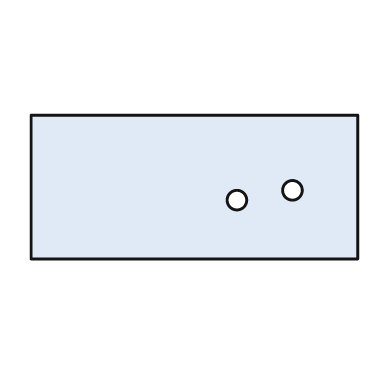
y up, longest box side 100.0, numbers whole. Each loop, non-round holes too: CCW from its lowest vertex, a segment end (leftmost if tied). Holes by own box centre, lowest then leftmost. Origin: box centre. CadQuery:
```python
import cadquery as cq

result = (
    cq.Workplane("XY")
    .moveTo(-50.0, -22.0)
    .lineTo(50.0, -22.0)
    .lineTo(50.0, 22.0)
    .lineTo(-50.0, 22.0)
    .close()
    .moveTo(13.0, -4.0)
    .circle(3.0)
    .moveTo(30.0, -1.0)
    .circle(3.0)
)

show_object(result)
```